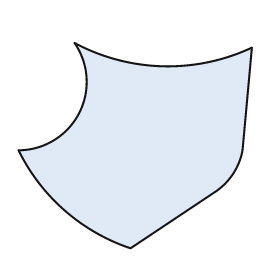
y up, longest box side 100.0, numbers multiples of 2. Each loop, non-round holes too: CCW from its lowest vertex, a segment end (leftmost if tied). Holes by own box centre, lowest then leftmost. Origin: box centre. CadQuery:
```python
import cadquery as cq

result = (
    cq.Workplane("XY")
    .moveTo(-2.0, -44.0)
    .lineTo(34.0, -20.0)
    .threePointArc((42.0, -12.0), (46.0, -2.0))
    .lineTo(50.0, 42.0)
    .threePointArc((12.0, 34.0), (-26.0, 44.0))
    .threePointArc((-24.0, 14.0), (-50.0, -2.0))
    .threePointArc((-30.0, -28.0), (-2.0, -44.0))
    .close()
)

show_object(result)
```